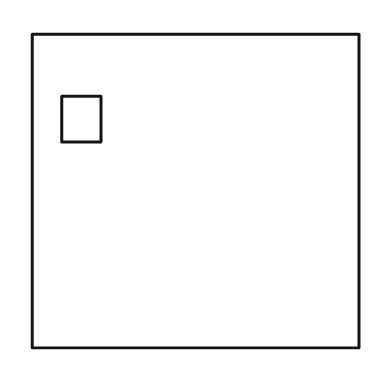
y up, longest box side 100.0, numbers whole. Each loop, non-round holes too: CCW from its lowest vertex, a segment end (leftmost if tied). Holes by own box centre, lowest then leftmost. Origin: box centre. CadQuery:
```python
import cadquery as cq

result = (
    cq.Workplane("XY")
    .moveTo(-50.0, -48.0)
    .lineTo(50.0, -48.0)
    .lineTo(50.0, 48.0)
    .lineTo(-50.0, 48.0)
    .close()
    .moveTo(-41.0, 15.0)
    .lineTo(-29.0, 15.0)
    .lineTo(-29.0, 29.0)
    .lineTo(-41.0, 29.0)
    .close()
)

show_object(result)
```